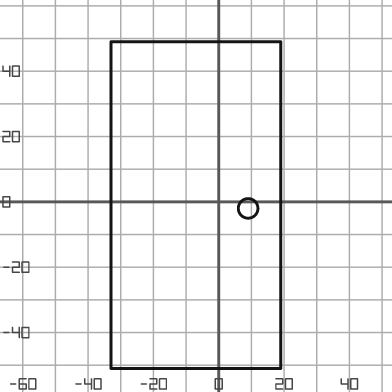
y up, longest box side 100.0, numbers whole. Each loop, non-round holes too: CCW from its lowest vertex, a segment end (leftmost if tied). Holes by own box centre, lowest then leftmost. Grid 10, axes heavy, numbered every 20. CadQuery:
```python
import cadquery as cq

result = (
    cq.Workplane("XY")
    .moveTo(-33.0, -51.0)
    .lineTo(19.0, -51.0)
    .lineTo(19.0, 49.0)
    .lineTo(-33.0, 49.0)
    .close()
    .moveTo(9.0, -2.0)
    .circle(3.0)
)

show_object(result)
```